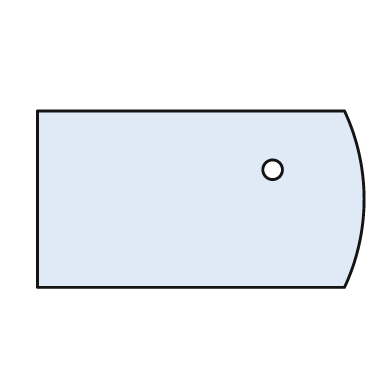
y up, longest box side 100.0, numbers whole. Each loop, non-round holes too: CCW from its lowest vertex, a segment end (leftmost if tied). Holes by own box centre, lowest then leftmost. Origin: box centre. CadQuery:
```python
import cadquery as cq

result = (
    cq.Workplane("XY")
    .moveTo(-50.0, -27.0)
    .lineTo(44.0, -27.0)
    .threePointArc((50.0, 0.0), (44.0, 27.0))
    .lineTo(-50.0, 27.0)
    .close()
    .moveTo(22.0, 9.0)
    .circle(3.0)
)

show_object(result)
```